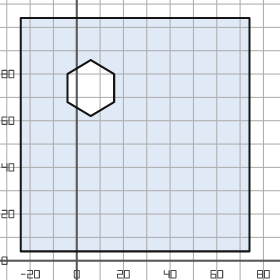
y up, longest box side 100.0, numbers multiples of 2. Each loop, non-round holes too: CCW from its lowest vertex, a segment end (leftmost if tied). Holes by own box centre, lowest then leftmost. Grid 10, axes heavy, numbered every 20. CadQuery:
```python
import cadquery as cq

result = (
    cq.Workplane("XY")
    .moveTo(-24.0, 4.0)
    .lineTo(74.0, 4.0)
    .lineTo(74.0, 104.0)
    .lineTo(-24.0, 104.0)
    .close()
    .moveTo(6.0, 62.0)
    .lineTo(16.0, 68.0)
    .lineTo(16.0, 80.0)
    .lineTo(6.0, 86.0)
    .lineTo(-4.0, 80.0)
    .lineTo(-4.0, 68.0)
    .close()
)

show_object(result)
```